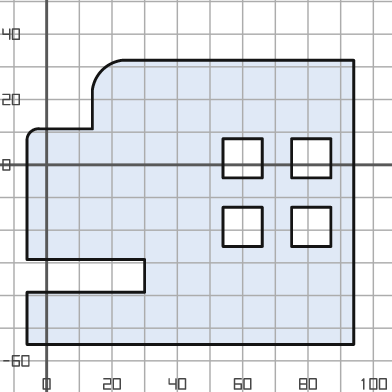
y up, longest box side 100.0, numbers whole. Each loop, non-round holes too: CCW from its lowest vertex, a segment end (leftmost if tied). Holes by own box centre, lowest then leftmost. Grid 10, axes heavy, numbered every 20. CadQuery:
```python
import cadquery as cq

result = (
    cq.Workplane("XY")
    .moveTo(-6.0, -55.0)
    .lineTo(94.0, -55.0)
    .lineTo(94.0, 32.0)
    .lineTo(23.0, 32.0)
    .threePointArc((17.0, 29.0), (14.0, 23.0))
    .lineTo(14.0, 11.0)
    .lineTo(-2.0, 11.0)
    .threePointArc((-5.0, 10.0), (-6.0, 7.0))
    .lineTo(-6.0, -29.0)
    .lineTo(30.0, -29.0)
    .lineTo(30.0, -39.0)
    .lineTo(-6.0, -39.0)
    .close()
    .moveTo(54.0, -25.0)
    .lineTo(66.0, -25.0)
    .lineTo(66.0, -13.0)
    .lineTo(54.0, -13.0)
    .close()
    .moveTo(75.0, -25.0)
    .lineTo(87.0, -25.0)
    .lineTo(87.0, -13.0)
    .lineTo(75.0, -13.0)
    .close()
    .moveTo(54.0, -4.0)
    .lineTo(66.0, -4.0)
    .lineTo(66.0, 8.0)
    .lineTo(54.0, 8.0)
    .close()
    .moveTo(75.0, -4.0)
    .lineTo(87.0, -4.0)
    .lineTo(87.0, 8.0)
    .lineTo(75.0, 8.0)
    .close()
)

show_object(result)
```